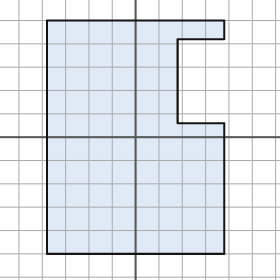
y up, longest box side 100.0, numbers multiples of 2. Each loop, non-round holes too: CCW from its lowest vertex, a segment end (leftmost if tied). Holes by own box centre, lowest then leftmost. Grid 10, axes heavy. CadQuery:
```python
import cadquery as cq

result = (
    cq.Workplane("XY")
    .moveTo(-38.0, -50.0)
    .lineTo(38.0, -50.0)
    .lineTo(38.0, 6.0)
    .lineTo(18.0, 6.0)
    .lineTo(18.0, 42.0)
    .lineTo(38.0, 42.0)
    .lineTo(38.0, 50.0)
    .lineTo(-38.0, 50.0)
    .close()
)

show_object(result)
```